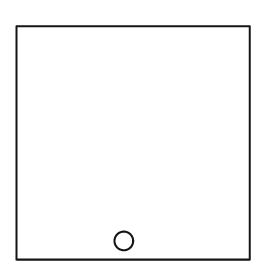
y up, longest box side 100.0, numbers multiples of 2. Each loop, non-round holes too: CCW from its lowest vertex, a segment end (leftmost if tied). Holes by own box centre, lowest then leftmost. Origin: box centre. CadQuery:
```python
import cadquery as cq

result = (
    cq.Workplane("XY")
    .moveTo(-50.0, -50.0)
    .lineTo(50.0, -50.0)
    .lineTo(50.0, 50.0)
    .lineTo(-50.0, 50.0)
    .close()
    .moveTo(-4.0, -42.0)
    .circle(4.0)
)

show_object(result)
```